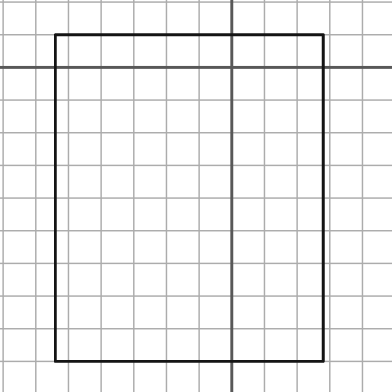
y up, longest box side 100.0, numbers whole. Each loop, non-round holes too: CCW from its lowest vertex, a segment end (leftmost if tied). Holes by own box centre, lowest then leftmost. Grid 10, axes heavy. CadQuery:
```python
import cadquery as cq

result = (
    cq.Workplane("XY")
    .moveTo(-54.0, -90.0)
    .lineTo(28.0, -90.0)
    .lineTo(28.0, 10.0)
    .lineTo(-54.0, 10.0)
    .close()
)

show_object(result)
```